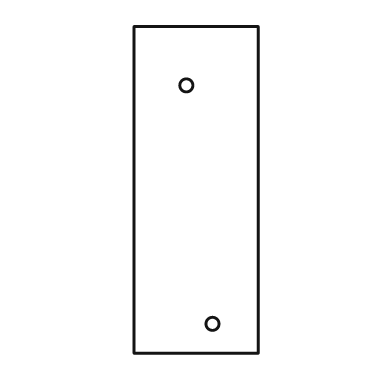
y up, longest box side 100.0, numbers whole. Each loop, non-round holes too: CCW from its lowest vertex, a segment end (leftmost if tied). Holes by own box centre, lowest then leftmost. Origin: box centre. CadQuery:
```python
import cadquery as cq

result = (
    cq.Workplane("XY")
    .moveTo(-19.0, -50.0)
    .lineTo(19.0, -50.0)
    .lineTo(19.0, 50.0)
    .lineTo(-19.0, 50.0)
    .close()
    .moveTo(5.0, -41.0)
    .circle(2.0)
    .moveTo(-3.0, 32.0)
    .circle(2.0)
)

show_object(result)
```